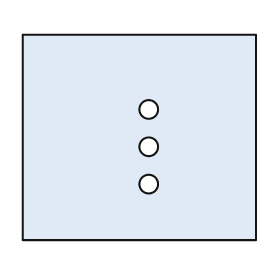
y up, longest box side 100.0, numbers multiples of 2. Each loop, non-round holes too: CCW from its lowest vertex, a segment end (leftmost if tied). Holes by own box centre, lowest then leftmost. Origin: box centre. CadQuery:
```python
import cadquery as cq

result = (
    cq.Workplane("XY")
    .moveTo(-50.0, -44.0)
    .lineTo(50.0, -44.0)
    .lineTo(50.0, 44.0)
    .lineTo(-50.0, 44.0)
    .close()
    .moveTo(4.0, -20.0)
    .circle(4.0)
    .moveTo(4.0, -4.0)
    .circle(4.0)
    .moveTo(4.0, 12.0)
    .circle(4.0)
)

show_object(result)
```